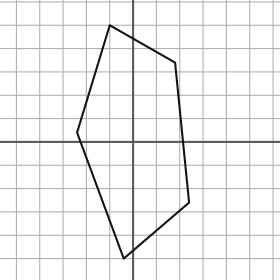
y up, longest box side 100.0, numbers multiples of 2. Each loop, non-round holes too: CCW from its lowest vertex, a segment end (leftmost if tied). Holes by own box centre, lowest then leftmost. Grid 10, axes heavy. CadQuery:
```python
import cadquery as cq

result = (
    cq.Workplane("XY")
    .moveTo(-4.0, -50.0)
    .lineTo(24.0, -26.0)
    .lineTo(18.0, 34.0)
    .lineTo(-10.0, 50.0)
    .lineTo(-24.0, 4.0)
    .close()
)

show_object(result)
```